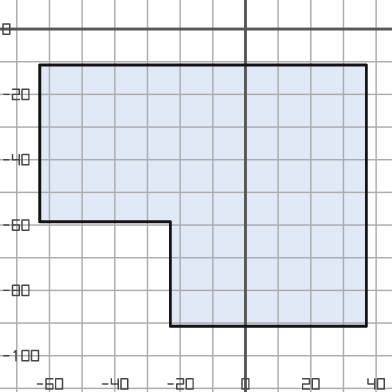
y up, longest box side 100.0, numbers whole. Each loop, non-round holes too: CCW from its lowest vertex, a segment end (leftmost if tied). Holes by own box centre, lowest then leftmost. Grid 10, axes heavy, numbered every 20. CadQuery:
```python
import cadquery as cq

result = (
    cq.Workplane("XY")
    .moveTo(-23.0, -91.0)
    .lineTo(37.0, -91.0)
    .lineTo(37.0, -11.0)
    .lineTo(-63.0, -11.0)
    .lineTo(-63.0, -59.0)
    .lineTo(-23.0, -59.0)
    .close()
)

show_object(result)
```